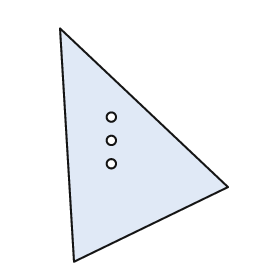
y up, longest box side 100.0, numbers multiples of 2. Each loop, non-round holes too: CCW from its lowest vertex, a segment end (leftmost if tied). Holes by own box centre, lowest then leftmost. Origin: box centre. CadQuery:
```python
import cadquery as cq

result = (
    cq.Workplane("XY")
    .moveTo(-30.0, -50.0)
    .lineTo(36.0, -18.0)
    .lineTo(-36.0, 50.0)
    .close()
    .moveTo(-14.0, -8.0)
    .circle(2.0)
    .moveTo(-14.0, 2.0)
    .circle(2.0)
    .moveTo(-14.0, 12.0)
    .circle(2.0)
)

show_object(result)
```